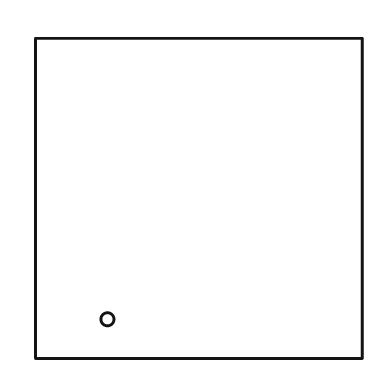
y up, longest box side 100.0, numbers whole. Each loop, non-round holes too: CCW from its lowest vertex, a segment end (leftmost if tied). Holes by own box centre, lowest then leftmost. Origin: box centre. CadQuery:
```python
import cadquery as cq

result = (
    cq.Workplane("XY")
    .moveTo(-50.0, -49.0)
    .lineTo(50.0, -49.0)
    .lineTo(50.0, 49.0)
    .lineTo(-50.0, 49.0)
    .close()
    .moveTo(-28.0, -37.0)
    .circle(2.0)
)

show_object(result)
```